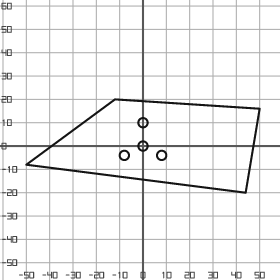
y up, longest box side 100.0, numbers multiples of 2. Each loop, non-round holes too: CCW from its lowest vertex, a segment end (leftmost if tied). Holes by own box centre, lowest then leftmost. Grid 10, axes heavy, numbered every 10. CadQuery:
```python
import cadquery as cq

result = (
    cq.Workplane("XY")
    .moveTo(44.0, -20.0)
    .lineTo(50.0, 16.0)
    .lineTo(-12.0, 20.0)
    .lineTo(-50.0, -8.0)
    .close()
    .moveTo(-8.0, -4.0)
    .circle(2.0)
    .moveTo(8.0, -4.0)
    .circle(2.0)
    .moveTo(0.0, 0.0)
    .circle(2.0)
    .moveTo(0.0, 10.0)
    .circle(2.0)
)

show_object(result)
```